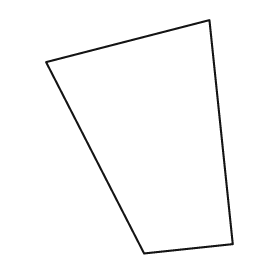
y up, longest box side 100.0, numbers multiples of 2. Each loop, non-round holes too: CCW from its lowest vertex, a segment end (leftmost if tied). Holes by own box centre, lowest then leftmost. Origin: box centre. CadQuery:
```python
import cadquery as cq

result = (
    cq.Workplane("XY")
    .moveTo(2.0, -50.0)
    .lineTo(40.0, -46.0)
    .lineTo(30.0, 50.0)
    .lineTo(-40.0, 32.0)
    .close()
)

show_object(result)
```